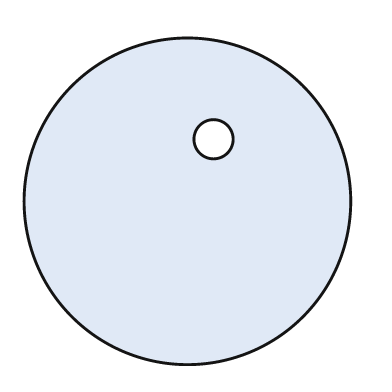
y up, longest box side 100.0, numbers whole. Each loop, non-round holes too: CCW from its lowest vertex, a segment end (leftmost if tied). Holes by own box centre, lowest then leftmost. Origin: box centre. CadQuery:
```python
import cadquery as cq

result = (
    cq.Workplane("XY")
    .moveTo(0.0, 0.0)
    .circle(50.0)
    .moveTo(8.0, 19.0)
    .circle(6.0)
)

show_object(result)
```